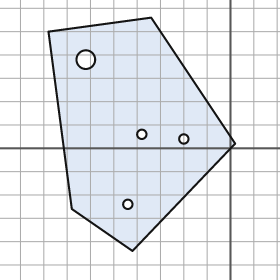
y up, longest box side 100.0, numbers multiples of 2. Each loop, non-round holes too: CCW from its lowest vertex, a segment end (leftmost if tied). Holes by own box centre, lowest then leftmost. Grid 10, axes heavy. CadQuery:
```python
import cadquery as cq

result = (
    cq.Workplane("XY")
    .moveTo(-42.0, -44.0)
    .lineTo(2.0, 2.0)
    .lineTo(-34.0, 56.0)
    .lineTo(-78.0, 50.0)
    .lineTo(-68.0, -26.0)
    .close()
    .moveTo(-44.0, -24.0)
    .circle(2.0)
    .moveTo(-20.0, 4.0)
    .circle(2.0)
    .moveTo(-38.0, 6.0)
    .circle(2.0)
    .moveTo(-62.0, 38.0)
    .circle(4.0)
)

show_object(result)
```